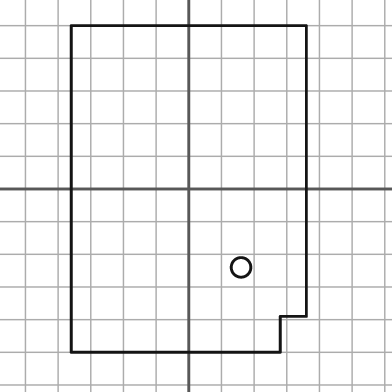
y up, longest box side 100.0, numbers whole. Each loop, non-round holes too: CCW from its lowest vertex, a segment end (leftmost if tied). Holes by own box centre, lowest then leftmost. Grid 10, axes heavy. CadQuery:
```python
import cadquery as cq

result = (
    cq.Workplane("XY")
    .moveTo(-36.0, -50.0)
    .lineTo(28.0, -50.0)
    .lineTo(28.0, -39.0)
    .lineTo(36.0, -39.0)
    .lineTo(36.0, 50.0)
    .lineTo(-36.0, 50.0)
    .close()
    .moveTo(16.0, -24.0)
    .circle(3.0)
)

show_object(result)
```